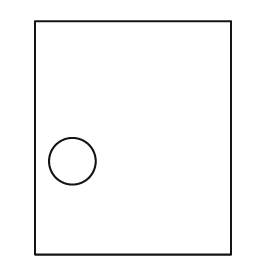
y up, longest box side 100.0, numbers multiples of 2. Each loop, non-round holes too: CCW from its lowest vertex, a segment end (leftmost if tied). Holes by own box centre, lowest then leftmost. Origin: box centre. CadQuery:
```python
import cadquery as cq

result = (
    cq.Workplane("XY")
    .moveTo(-42.0, -50.0)
    .lineTo(42.0, -50.0)
    .lineTo(42.0, 50.0)
    .lineTo(-42.0, 50.0)
    .close()
    .moveTo(-26.0, -10.0)
    .circle(10.0)
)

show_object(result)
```